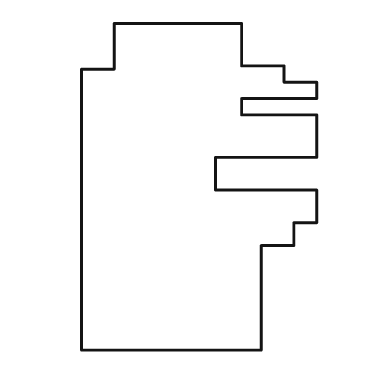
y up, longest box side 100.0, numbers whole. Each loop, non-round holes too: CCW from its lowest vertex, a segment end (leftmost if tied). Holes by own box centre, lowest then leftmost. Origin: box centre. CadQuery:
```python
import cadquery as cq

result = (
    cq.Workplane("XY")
    .moveTo(-36.0, -50.0)
    .lineTo(19.0, -50.0)
    .lineTo(19.0, -18.0)
    .lineTo(29.0, -18.0)
    .lineTo(29.0, -11.0)
    .lineTo(36.0, -11.0)
    .lineTo(36.0, -1.0)
    .lineTo(5.0, -1.0)
    .lineTo(5.0, 9.0)
    .lineTo(36.0, 9.0)
    .lineTo(36.0, 22.0)
    .lineTo(13.0, 22.0)
    .lineTo(13.0, 27.0)
    .lineTo(36.0, 27.0)
    .lineTo(36.0, 32.0)
    .lineTo(26.0, 32.0)
    .lineTo(26.0, 37.0)
    .lineTo(13.0, 37.0)
    .lineTo(13.0, 50.0)
    .lineTo(-26.0, 50.0)
    .lineTo(-26.0, 36.0)
    .lineTo(-36.0, 36.0)
    .close()
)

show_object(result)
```